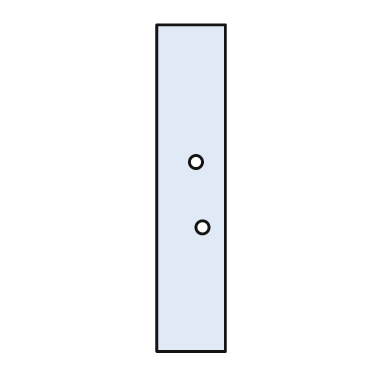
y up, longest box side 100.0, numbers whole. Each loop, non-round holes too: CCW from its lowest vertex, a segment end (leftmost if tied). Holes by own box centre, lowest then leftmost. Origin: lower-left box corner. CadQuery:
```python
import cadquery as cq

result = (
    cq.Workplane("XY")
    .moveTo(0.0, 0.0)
    .lineTo(21.0, 0.0)
    .lineTo(21.0, 100.0)
    .lineTo(0.0, 100.0)
    .close()
    .moveTo(14.0, 38.0)
    .circle(2.0)
    .moveTo(12.0, 58.0)
    .circle(2.0)
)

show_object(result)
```